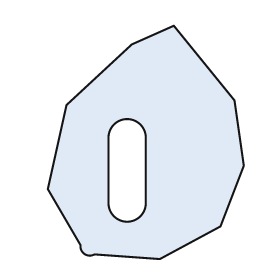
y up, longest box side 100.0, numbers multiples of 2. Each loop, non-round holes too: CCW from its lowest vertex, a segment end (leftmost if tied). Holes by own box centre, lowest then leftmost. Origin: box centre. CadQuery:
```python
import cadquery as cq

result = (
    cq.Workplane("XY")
    .moveTo(6.0, -50.0)
    .lineTo(32.0, -36.0)
    .lineTo(42.0, -10.0)
    .lineTo(38.0, 18.0)
    .lineTo(12.0, 50.0)
    .lineTo(-6.0, 42.0)
    .lineTo(-34.0, 16.0)
    .lineTo(-42.0, -20.0)
    .lineTo(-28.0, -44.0)
    .threePointArc((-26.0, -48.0), (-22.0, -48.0))
    .close()
    .moveTo(-16.0, -26.0)
    .threePointArc((-8.0, -34.0), (0.0, -26.0))
    .lineTo(0.0, 2.0)
    .threePointArc((-8.0, 10.0), (-16.0, 2.0))
    .close()
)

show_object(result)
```